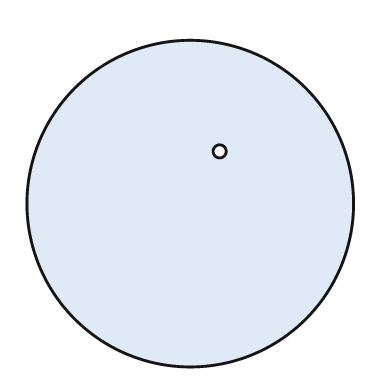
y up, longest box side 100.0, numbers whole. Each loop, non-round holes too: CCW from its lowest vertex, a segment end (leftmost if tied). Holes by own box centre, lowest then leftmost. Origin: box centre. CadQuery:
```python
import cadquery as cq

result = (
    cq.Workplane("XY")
    .moveTo(0.0, 0.0)
    .circle(50.0)
    .moveTo(9.0, 16.0)
    .circle(2.0)
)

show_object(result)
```